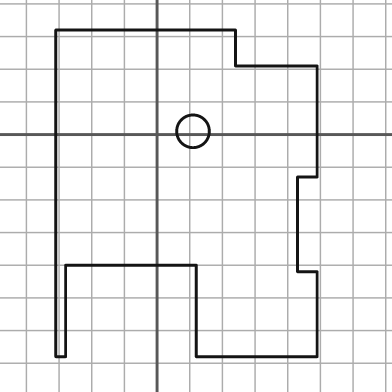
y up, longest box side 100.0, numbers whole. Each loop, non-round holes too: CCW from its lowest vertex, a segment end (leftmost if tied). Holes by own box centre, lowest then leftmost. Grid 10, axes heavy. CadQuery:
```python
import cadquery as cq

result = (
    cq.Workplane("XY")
    .moveTo(-31.0, -68.0)
    .lineTo(-28.0, -68.0)
    .lineTo(-28.0, -40.0)
    .lineTo(12.0, -40.0)
    .lineTo(12.0, -68.0)
    .lineTo(49.0, -68.0)
    .lineTo(49.0, -42.0)
    .lineTo(43.0, -42.0)
    .lineTo(43.0, -13.0)
    .lineTo(49.0, -13.0)
    .lineTo(49.0, 21.0)
    .lineTo(24.0, 21.0)
    .lineTo(24.0, 32.0)
    .lineTo(-31.0, 32.0)
    .close()
    .moveTo(11.0, 1.0)
    .circle(5.0)
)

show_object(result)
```